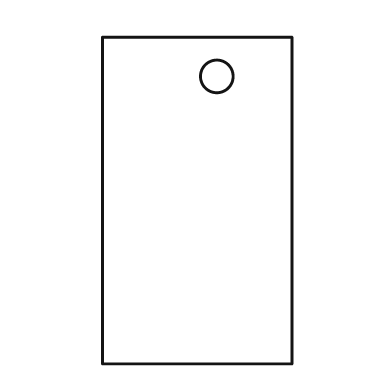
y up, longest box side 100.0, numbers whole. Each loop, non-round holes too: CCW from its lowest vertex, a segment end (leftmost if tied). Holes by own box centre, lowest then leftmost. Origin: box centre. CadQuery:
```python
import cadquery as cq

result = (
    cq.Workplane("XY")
    .moveTo(-29.0, -50.0)
    .lineTo(29.0, -50.0)
    .lineTo(29.0, 50.0)
    .lineTo(-29.0, 50.0)
    .close()
    .moveTo(6.0, 38.0)
    .circle(5.0)
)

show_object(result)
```